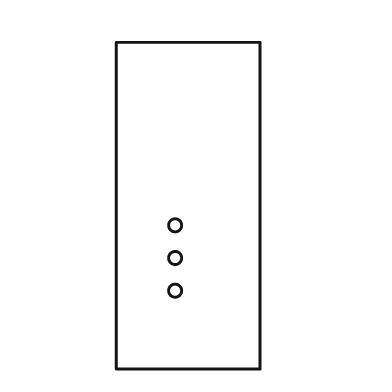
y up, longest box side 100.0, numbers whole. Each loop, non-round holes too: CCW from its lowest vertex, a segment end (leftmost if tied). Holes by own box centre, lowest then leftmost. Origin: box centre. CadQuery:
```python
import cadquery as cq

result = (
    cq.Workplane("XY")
    .moveTo(-22.0, -50.0)
    .lineTo(22.0, -50.0)
    .lineTo(22.0, 50.0)
    .lineTo(-22.0, 50.0)
    .close()
    .moveTo(-4.0, -26.0)
    .circle(2.0)
    .moveTo(-4.0, -16.0)
    .circle(2.0)
    .moveTo(-4.0, -6.0)
    .circle(2.0)
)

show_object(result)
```